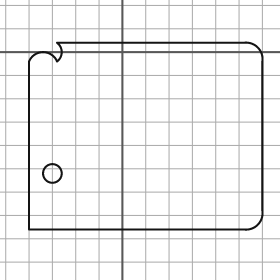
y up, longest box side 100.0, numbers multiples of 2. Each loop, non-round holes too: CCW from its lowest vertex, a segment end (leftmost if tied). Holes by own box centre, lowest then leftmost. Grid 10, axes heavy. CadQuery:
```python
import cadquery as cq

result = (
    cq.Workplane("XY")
    .moveTo(-40.0, -76.0)
    .lineTo(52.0, -76.0)
    .threePointArc((58.0, -74.0), (60.0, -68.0))
    .lineTo(60.0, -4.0)
    .threePointArc((58.0, 2.0), (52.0, 4.0))
    .lineTo(-28.0, 4.0)
    .threePointArc((-26.0, 0.0), (-28.0, -4.0))
    .threePointArc((-34.0, 0.0), (-40.0, -4.0))
    .close()
    .moveTo(-30.0, -52.0)
    .circle(4.0)
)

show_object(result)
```